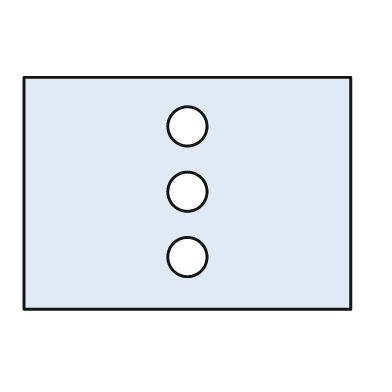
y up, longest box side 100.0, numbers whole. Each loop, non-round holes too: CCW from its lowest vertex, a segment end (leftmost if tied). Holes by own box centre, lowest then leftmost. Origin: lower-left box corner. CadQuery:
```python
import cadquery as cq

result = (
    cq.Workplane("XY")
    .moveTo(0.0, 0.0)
    .lineTo(100.0, 0.0)
    .lineTo(100.0, 71.0)
    .lineTo(0.0, 71.0)
    .close()
    .moveTo(50.0, 16.0)
    .circle(6.0)
    .moveTo(50.0, 36.0)
    .circle(6.0)
    .moveTo(50.0, 56.0)
    .circle(6.0)
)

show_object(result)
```